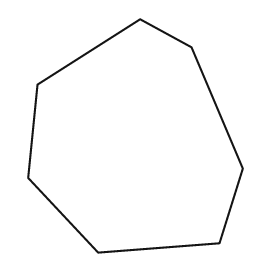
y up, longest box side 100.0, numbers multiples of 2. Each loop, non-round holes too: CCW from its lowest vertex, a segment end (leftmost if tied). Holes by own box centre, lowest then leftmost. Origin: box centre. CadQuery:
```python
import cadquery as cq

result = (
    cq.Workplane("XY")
    .moveTo(-16.0, -50.0)
    .lineTo(36.0, -46.0)
    .lineTo(46.0, -14.0)
    .lineTo(24.0, 38.0)
    .lineTo(2.0, 50.0)
    .lineTo(-42.0, 22.0)
    .lineTo(-46.0, -18.0)
    .close()
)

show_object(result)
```